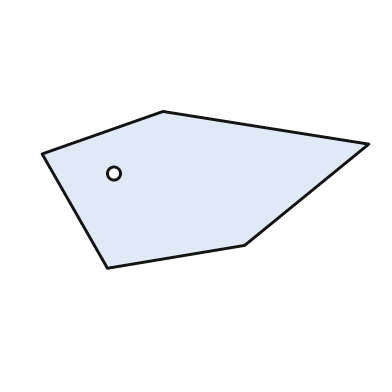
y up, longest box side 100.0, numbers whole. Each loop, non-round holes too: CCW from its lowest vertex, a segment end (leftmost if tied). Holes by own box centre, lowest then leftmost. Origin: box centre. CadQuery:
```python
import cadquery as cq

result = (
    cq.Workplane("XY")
    .moveTo(-30.0, -24.0)
    .lineTo(12.0, -17.0)
    .lineTo(50.0, 14.0)
    .lineTo(-13.0, 24.0)
    .lineTo(-50.0, 11.0)
    .close()
    .moveTo(-28.0, 5.0)
    .circle(2.0)
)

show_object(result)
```